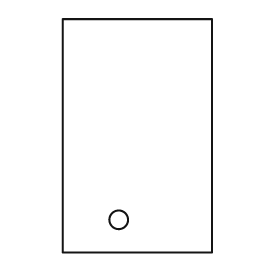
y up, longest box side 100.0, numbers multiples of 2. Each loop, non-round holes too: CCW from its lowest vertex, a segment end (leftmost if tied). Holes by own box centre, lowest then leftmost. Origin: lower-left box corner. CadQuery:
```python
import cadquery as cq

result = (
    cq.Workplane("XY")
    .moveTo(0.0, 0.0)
    .lineTo(64.0, 0.0)
    .lineTo(64.0, 100.0)
    .lineTo(0.0, 100.0)
    .close()
    .moveTo(24.0, 14.0)
    .circle(4.0)
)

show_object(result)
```